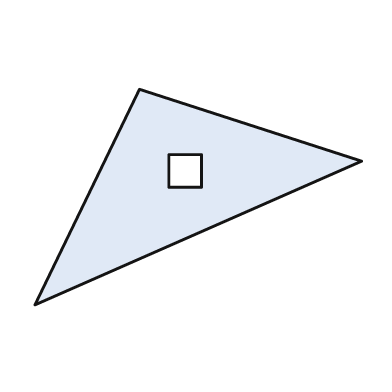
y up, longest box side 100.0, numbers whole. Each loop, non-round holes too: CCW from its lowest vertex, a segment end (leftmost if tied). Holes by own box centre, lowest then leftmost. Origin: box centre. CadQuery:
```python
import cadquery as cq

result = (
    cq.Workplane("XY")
    .moveTo(-50.0, -33.0)
    .lineTo(50.0, 11.0)
    .lineTo(-18.0, 33.0)
    .close()
    .moveTo(-9.0, 3.0)
    .lineTo(1.0, 3.0)
    .lineTo(1.0, 13.0)
    .lineTo(-9.0, 13.0)
    .close()
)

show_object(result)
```